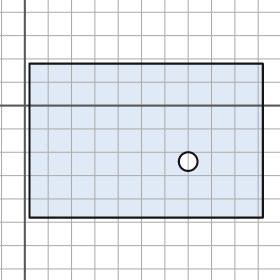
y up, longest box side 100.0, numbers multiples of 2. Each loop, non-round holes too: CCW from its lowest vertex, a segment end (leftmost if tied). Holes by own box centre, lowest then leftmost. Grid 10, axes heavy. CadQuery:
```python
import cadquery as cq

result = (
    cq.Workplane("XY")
    .moveTo(2.0, -48.0)
    .lineTo(102.0, -48.0)
    .lineTo(102.0, 18.0)
    .lineTo(2.0, 18.0)
    .close()
    .moveTo(70.0, -24.0)
    .circle(4.0)
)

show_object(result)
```